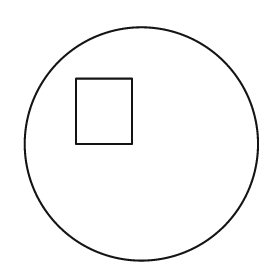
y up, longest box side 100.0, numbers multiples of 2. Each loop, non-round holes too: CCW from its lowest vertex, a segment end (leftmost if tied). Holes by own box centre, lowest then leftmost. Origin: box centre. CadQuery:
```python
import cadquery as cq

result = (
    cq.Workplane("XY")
    .moveTo(0.0, 0.0)
    .circle(50.0)
    .moveTo(-28.0, 0.0)
    .lineTo(-4.0, 0.0)
    .lineTo(-4.0, 28.0)
    .lineTo(-28.0, 28.0)
    .close()
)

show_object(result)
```